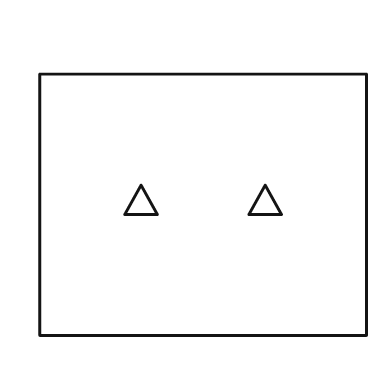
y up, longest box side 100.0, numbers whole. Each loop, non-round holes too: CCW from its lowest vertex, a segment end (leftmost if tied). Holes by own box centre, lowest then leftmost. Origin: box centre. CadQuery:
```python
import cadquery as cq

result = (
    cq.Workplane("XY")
    .moveTo(-50.0, -40.0)
    .lineTo(50.0, -40.0)
    .lineTo(50.0, 40.0)
    .lineTo(-50.0, 40.0)
    .close()
    .moveTo(-24.0, -3.0)
    .lineTo(-14.0, -3.0)
    .lineTo(-19.0, 6.0)
    .close()
    .moveTo(14.0, -3.0)
    .lineTo(24.0, -3.0)
    .lineTo(19.0, 6.0)
    .close()
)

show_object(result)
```